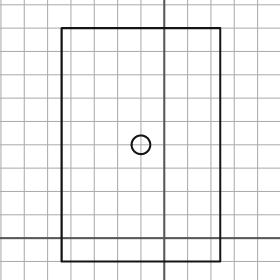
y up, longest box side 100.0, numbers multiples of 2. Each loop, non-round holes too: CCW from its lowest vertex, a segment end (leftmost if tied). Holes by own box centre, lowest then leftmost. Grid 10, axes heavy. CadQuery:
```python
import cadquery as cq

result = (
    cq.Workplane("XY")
    .moveTo(-44.0, -10.0)
    .lineTo(24.0, -10.0)
    .lineTo(24.0, 90.0)
    .lineTo(-44.0, 90.0)
    .close()
    .moveTo(-10.0, 40.0)
    .circle(4.0)
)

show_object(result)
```